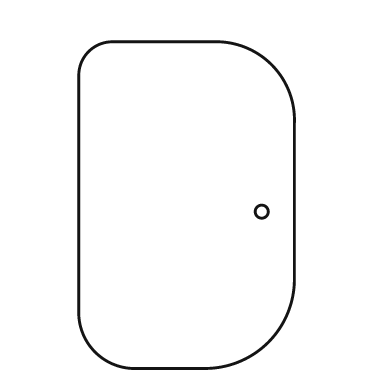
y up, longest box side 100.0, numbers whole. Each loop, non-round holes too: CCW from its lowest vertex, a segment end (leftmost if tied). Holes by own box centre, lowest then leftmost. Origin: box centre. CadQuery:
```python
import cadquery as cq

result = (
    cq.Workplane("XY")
    .moveTo(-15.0, -50.0)
    .lineTo(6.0, -50.0)
    .threePointArc((25.0, -42.0), (33.0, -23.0))
    .lineTo(33.0, 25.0)
    .threePointArc((26.0, 43.0), (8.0, 50.0))
    .lineTo(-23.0, 50.0)
    .threePointArc((-30.0, 47.0), (-33.0, 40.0))
    .lineTo(-33.0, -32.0)
    .threePointArc((-28.0, -45.0), (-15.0, -50.0))
    .close()
    .moveTo(23.0, -2.0)
    .circle(2.0)
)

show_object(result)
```